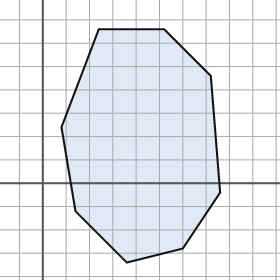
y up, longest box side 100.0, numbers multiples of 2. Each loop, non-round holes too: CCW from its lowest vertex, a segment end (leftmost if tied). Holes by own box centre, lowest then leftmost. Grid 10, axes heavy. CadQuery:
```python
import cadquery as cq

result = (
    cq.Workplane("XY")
    .moveTo(36.0, -34.0)
    .lineTo(60.0, -28.0)
    .lineTo(76.0, -4.0)
    .lineTo(72.0, 46.0)
    .lineTo(52.0, 66.0)
    .lineTo(24.0, 66.0)
    .lineTo(8.0, 24.0)
    .lineTo(14.0, -12.0)
    .close()
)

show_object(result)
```